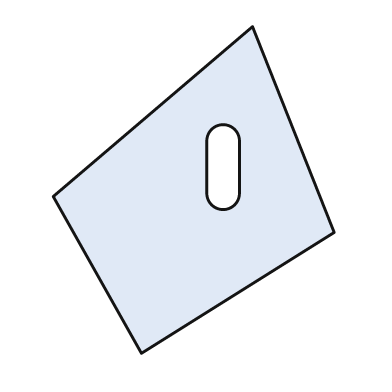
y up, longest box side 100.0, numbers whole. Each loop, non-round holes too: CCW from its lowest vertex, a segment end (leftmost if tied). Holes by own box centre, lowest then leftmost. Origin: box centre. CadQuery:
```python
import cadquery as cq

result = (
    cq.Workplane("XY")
    .moveTo(-16.0, -50.0)
    .lineTo(43.0, -13.0)
    .lineTo(18.0, 50.0)
    .lineTo(-43.0, -2.0)
    .close()
    .moveTo(4.0, -1.0)
    .threePointArc((9.0, -6.0), (14.0, -1.0))
    .lineTo(14.0, 15.0)
    .threePointArc((9.0, 20.0), (4.0, 15.0))
    .close()
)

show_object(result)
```